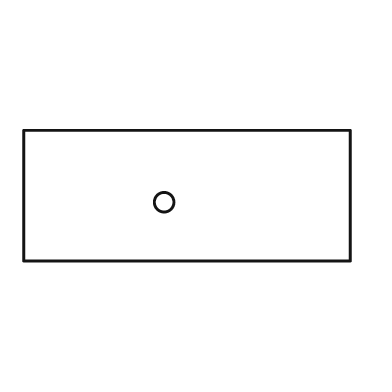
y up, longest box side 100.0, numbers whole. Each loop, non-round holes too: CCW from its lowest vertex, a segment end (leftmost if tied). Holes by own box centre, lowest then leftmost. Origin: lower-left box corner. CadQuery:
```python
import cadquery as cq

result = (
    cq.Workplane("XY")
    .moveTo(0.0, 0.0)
    .lineTo(100.0, 0.0)
    .lineTo(100.0, 40.0)
    .lineTo(0.0, 40.0)
    .close()
    .moveTo(43.0, 18.0)
    .circle(3.0)
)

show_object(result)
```